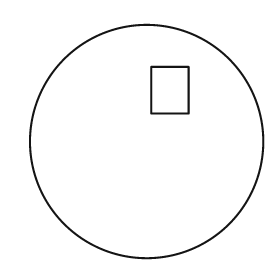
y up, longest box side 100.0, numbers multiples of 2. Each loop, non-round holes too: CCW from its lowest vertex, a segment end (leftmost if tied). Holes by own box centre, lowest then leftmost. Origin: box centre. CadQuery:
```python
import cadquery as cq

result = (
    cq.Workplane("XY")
    .moveTo(0.0, 0.0)
    .circle(50.0)
    .moveTo(2.0, 12.0)
    .lineTo(18.0, 12.0)
    .lineTo(18.0, 32.0)
    .lineTo(2.0, 32.0)
    .close()
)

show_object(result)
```